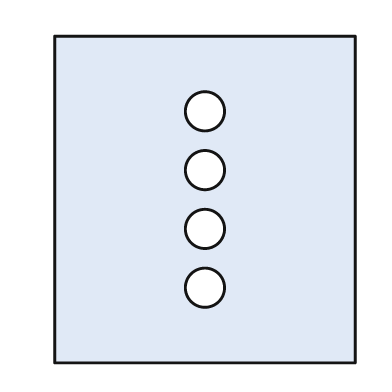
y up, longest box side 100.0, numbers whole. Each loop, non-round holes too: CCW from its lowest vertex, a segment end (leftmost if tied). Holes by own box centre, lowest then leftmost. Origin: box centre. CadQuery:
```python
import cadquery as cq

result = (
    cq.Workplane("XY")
    .moveTo(-46.0, -50.0)
    .lineTo(46.0, -50.0)
    .lineTo(46.0, 50.0)
    .lineTo(-46.0, 50.0)
    .close()
    .moveTo(0.0, -27.0)
    .circle(6.0)
    .moveTo(0.0, -9.0)
    .circle(6.0)
    .moveTo(0.0, 9.0)
    .circle(6.0)
    .moveTo(0.0, 27.0)
    .circle(6.0)
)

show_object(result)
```